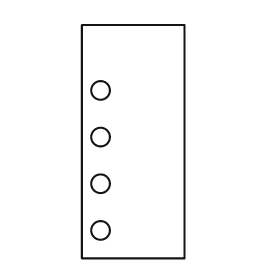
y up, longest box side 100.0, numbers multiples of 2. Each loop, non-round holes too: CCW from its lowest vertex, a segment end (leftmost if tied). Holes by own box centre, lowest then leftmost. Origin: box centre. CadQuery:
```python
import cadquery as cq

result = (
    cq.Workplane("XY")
    .moveTo(-22.0, -50.0)
    .lineTo(22.0, -50.0)
    .lineTo(22.0, 50.0)
    .lineTo(-22.0, 50.0)
    .close()
    .moveTo(-14.0, -38.0)
    .circle(4.0)
    .moveTo(-14.0, -18.0)
    .circle(4.0)
    .moveTo(-14.0, 2.0)
    .circle(4.0)
    .moveTo(-14.0, 22.0)
    .circle(4.0)
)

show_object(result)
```